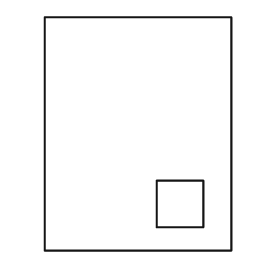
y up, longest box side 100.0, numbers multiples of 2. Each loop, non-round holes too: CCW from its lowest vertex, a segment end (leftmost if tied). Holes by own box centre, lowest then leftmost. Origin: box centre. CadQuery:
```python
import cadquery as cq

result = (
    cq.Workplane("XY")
    .moveTo(-40.0, -50.0)
    .lineTo(40.0, -50.0)
    .lineTo(40.0, 50.0)
    .lineTo(-40.0, 50.0)
    .close()
    .moveTo(8.0, -40.0)
    .lineTo(28.0, -40.0)
    .lineTo(28.0, -20.0)
    .lineTo(8.0, -20.0)
    .close()
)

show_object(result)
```